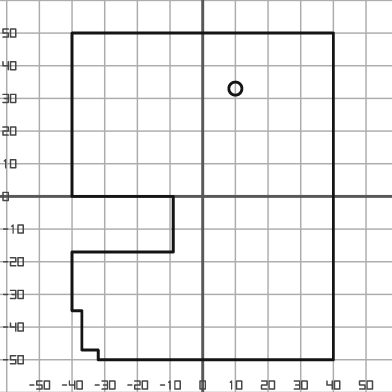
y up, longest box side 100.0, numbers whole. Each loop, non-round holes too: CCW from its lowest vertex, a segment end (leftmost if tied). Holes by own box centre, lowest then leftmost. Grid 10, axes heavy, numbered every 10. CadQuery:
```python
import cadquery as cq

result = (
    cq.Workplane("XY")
    .moveTo(-32.0, -50.0)
    .lineTo(40.0, -50.0)
    .lineTo(40.0, 50.0)
    .lineTo(-40.0, 50.0)
    .lineTo(-40.0, 0.0)
    .lineTo(-9.0, 0.0)
    .lineTo(-9.0, -17.0)
    .lineTo(-40.0, -17.0)
    .lineTo(-40.0, -35.0)
    .lineTo(-37.0, -35.0)
    .lineTo(-37.0, -47.0)
    .lineTo(-32.0, -47.0)
    .close()
    .moveTo(10.0, 33.0)
    .circle(2.0)
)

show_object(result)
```